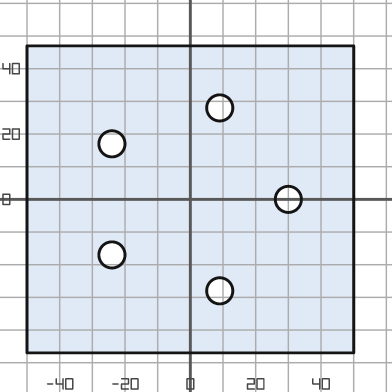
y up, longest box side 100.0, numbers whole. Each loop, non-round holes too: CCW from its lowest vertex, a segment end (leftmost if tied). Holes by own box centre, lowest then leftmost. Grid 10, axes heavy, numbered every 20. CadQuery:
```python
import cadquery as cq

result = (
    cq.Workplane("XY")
    .moveTo(-50.0, -47.0)
    .lineTo(50.0, -47.0)
    .lineTo(50.0, 47.0)
    .lineTo(-50.0, 47.0)
    .close()
    .moveTo(9.0, -28.0)
    .circle(4.0)
    .moveTo(-24.0, -17.0)
    .circle(4.0)
    .moveTo(30.0, 0.0)
    .circle(4.0)
    .moveTo(-24.0, 17.0)
    .circle(4.0)
    .moveTo(9.0, 28.0)
    .circle(4.0)
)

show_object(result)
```